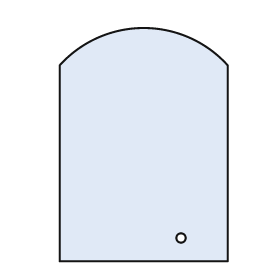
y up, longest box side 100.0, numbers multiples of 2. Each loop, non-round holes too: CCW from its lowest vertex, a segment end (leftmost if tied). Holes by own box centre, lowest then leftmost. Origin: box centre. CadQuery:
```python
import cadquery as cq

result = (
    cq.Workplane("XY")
    .moveTo(-36.0, -50.0)
    .lineTo(36.0, -50.0)
    .lineTo(36.0, 34.0)
    .threePointArc((0.0, 50.0), (-36.0, 34.0))
    .close()
    .moveTo(16.0, -40.0)
    .circle(2.0)
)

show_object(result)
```